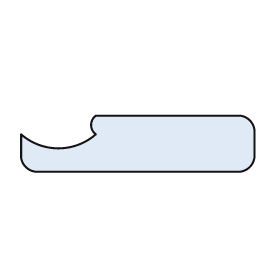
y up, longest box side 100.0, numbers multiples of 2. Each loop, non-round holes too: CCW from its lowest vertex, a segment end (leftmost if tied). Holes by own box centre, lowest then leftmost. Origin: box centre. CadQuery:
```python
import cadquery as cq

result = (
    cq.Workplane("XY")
    .moveTo(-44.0, -12.0)
    .lineTo(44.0, -12.0)
    .threePointArc((48.0, -10.0), (50.0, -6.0))
    .lineTo(50.0, 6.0)
    .threePointArc((48.0, 10.0), (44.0, 12.0))
    .lineTo(-18.0, 12.0)
    .threePointArc((-20.0, 8.0), (-18.0, 4.0))
    .threePointArc((-34.0, -2.0), (-50.0, 4.0))
    .lineTo(-50.0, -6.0)
    .threePointArc((-48.0, -10.0), (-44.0, -12.0))
    .close()
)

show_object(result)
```